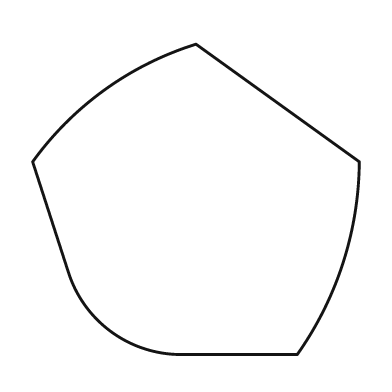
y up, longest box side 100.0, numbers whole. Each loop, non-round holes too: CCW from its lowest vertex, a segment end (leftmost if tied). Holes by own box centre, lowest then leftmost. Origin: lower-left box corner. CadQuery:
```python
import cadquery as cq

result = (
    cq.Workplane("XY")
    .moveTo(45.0, 0.0)
    .lineTo(81.0, 0.0)
    .threePointArc((95.0, 28.0), (100.0, 59.0))
    .lineTo(50.0, 95.0)
    .threePointArc((22.0, 81.0), (0.0, 59.0))
    .lineTo(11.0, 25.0)
    .threePointArc((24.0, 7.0), (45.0, 0.0))
    .close()
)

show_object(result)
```